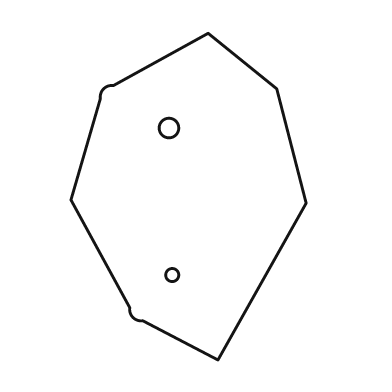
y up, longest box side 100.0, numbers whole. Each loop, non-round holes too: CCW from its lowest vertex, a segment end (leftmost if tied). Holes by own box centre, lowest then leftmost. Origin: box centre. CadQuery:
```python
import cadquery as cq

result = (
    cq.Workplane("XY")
    .moveTo(9.0, -50.0)
    .lineTo(36.0, -2.0)
    .lineTo(27.0, 33.0)
    .lineTo(6.0, 50.0)
    .lineTo(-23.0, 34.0)
    .threePointArc((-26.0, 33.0), (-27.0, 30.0))
    .lineTo(-36.0, -1.0)
    .lineTo(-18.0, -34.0)
    .threePointArc((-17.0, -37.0), (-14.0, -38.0))
    .close()
    .moveTo(-5.0, -24.0)
    .circle(2.0)
    .moveTo(-6.0, 21.0)
    .circle(3.0)
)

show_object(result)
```